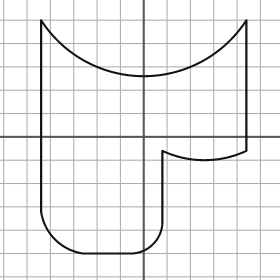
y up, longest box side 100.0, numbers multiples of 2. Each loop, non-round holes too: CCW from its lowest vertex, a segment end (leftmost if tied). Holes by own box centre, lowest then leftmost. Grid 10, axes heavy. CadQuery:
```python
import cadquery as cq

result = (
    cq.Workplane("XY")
    .moveTo(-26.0, -50.0)
    .lineTo(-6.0, -50.0)
    .threePointArc((4.0, -46.0), (8.0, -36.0))
    .lineTo(8.0, -6.0)
    .threePointArc((26.0, -10.0), (44.0, -6.0))
    .lineTo(44.0, 50.0)
    .threePointArc((0.0, 26.0), (-44.0, 50.0))
    .lineTo(-44.0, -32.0)
    .threePointArc((-38.0, -44.0), (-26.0, -50.0))
    .close()
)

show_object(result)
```